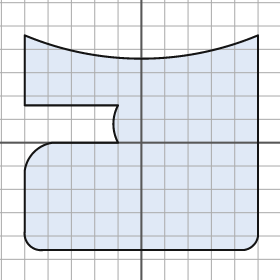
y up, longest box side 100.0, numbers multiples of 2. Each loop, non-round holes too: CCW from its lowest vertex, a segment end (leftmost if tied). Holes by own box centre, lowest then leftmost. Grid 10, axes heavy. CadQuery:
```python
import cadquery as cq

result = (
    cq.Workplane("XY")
    .moveTo(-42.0, -46.0)
    .lineTo(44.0, -46.0)
    .threePointArc((48.0, -44.0), (50.0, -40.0))
    .lineTo(50.0, 46.0)
    .threePointArc((0.0, 36.0), (-50.0, 46.0))
    .lineTo(-50.0, 16.0)
    .lineTo(-10.0, 16.0)
    .threePointArc((-12.0, 8.0), (-10.0, 0.0))
    .lineTo(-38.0, 0.0)
    .threePointArc((-46.0, -4.0), (-50.0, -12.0))
    .lineTo(-50.0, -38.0)
    .threePointArc((-48.0, -44.0), (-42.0, -46.0))
    .close()
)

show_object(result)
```